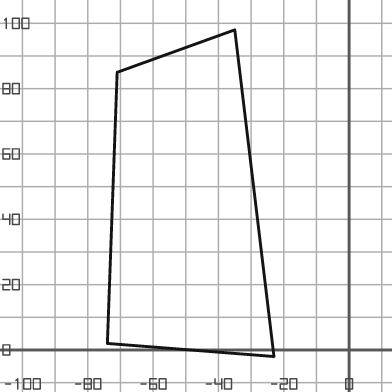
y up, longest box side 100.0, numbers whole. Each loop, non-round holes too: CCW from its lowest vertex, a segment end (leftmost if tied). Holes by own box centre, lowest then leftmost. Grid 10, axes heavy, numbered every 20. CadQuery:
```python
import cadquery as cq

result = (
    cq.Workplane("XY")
    .moveTo(-23.0, -2.0)
    .lineTo(-35.0, 98.0)
    .lineTo(-71.0, 85.0)
    .lineTo(-74.0, 2.0)
    .close()
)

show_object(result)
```